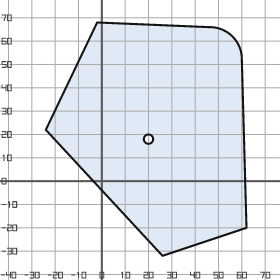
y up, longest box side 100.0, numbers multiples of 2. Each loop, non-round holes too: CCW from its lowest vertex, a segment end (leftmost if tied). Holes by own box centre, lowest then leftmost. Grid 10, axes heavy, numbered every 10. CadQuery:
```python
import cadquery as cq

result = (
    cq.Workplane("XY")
    .moveTo(26.0, -32.0)
    .lineTo(62.0, -20.0)
    .lineTo(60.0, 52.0)
    .threePointArc((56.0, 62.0), (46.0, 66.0))
    .lineTo(-2.0, 68.0)
    .lineTo(-24.0, 22.0)
    .close()
    .moveTo(20.0, 18.0)
    .circle(2.0)
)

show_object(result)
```